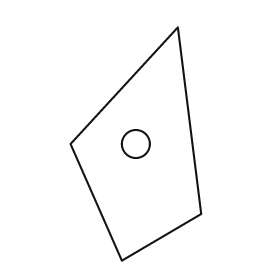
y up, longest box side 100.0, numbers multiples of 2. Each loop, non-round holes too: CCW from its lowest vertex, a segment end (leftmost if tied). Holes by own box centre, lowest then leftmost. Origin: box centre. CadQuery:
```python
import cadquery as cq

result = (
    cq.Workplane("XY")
    .moveTo(-6.0, -50.0)
    .lineTo(28.0, -30.0)
    .lineTo(18.0, 50.0)
    .lineTo(-28.0, 0.0)
    .close()
    .moveTo(0.0, 0.0)
    .circle(6.0)
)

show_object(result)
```